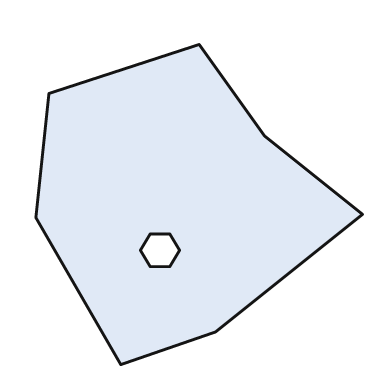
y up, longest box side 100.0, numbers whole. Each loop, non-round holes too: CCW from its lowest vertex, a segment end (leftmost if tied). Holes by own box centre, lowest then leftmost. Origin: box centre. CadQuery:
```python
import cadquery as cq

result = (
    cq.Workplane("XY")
    .moveTo(-24.0, -49.0)
    .lineTo(5.0, -39.0)
    .lineTo(50.0, -3.0)
    .lineTo(20.0, 21.0)
    .lineTo(0.0, 49.0)
    .lineTo(-46.0, 34.0)
    .lineTo(-50.0, -4.0)
    .close()
    .moveTo(-15.0, -19.0)
    .lineTo(-9.0, -19.0)
    .lineTo(-6.0, -14.0)
    .lineTo(-9.0, -9.0)
    .lineTo(-15.0, -9.0)
    .lineTo(-18.0, -14.0)
    .close()
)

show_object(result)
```